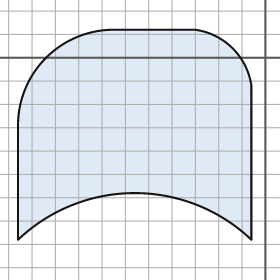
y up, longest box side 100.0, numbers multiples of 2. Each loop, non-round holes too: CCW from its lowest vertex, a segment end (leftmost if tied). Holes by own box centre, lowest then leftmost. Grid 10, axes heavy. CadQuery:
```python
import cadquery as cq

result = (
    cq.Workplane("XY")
    .moveTo(-106.0, -78.0)
    .threePointArc((-56.0, -58.0), (-6.0, -78.0))
    .lineTo(-6.0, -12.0)
    .threePointArc((-14.0, 4.0), (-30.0, 12.0))
    .lineTo(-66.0, 12.0)
    .threePointArc((-94.0, 0.0), (-106.0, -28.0))
    .close()
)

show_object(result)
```